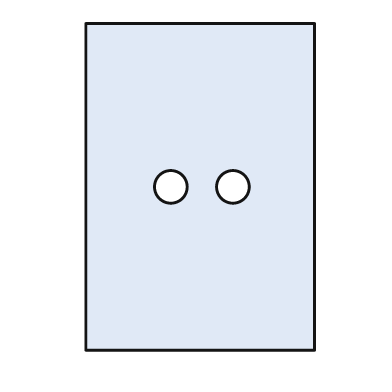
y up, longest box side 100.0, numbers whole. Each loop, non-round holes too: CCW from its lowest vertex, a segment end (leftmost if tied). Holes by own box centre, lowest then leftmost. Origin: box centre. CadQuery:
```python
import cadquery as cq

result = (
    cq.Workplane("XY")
    .moveTo(-35.0, -50.0)
    .lineTo(35.0, -50.0)
    .lineTo(35.0, 50.0)
    .lineTo(-35.0, 50.0)
    .close()
    .moveTo(-9.0, 0.0)
    .circle(5.0)
    .moveTo(10.0, 0.0)
    .circle(5.0)
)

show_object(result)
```